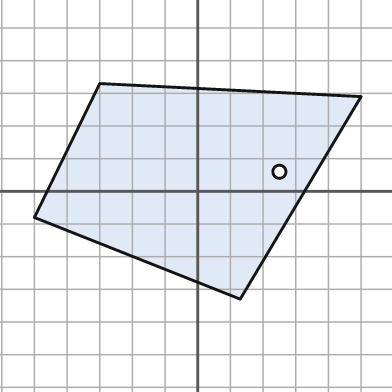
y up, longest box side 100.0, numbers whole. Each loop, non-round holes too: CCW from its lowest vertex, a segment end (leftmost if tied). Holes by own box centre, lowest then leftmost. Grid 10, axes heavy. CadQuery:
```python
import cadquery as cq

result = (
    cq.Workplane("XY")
    .moveTo(13.0, -33.0)
    .lineTo(50.0, 29.0)
    .lineTo(-30.0, 33.0)
    .lineTo(-50.0, -8.0)
    .close()
    .moveTo(25.0, 6.0)
    .circle(2.0)
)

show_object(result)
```